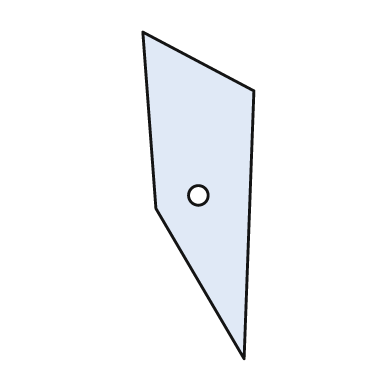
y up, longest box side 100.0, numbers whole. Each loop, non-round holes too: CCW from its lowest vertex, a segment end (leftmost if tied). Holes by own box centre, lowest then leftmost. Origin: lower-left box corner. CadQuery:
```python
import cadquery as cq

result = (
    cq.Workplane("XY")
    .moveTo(31.0, 0.0)
    .lineTo(34.0, 82.0)
    .lineTo(0.0, 100.0)
    .lineTo(4.0, 46.0)
    .close()
    .moveTo(17.0, 50.0)
    .circle(3.0)
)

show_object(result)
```